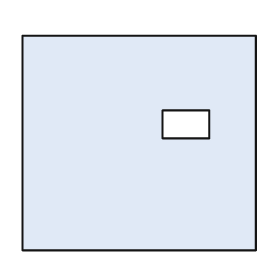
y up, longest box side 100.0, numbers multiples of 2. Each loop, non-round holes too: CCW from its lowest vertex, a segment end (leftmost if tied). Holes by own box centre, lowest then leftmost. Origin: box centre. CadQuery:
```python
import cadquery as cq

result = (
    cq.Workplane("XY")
    .moveTo(-50.0, -46.0)
    .lineTo(50.0, -46.0)
    .lineTo(50.0, 46.0)
    .lineTo(-50.0, 46.0)
    .close()
    .moveTo(10.0, 2.0)
    .lineTo(30.0, 2.0)
    .lineTo(30.0, 14.0)
    .lineTo(10.0, 14.0)
    .close()
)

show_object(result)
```